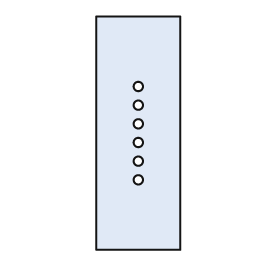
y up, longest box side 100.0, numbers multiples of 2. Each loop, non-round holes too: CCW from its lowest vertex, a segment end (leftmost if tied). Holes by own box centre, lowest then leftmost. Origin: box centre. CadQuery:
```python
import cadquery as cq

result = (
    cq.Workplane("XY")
    .moveTo(-18.0, -50.0)
    .lineTo(18.0, -50.0)
    .lineTo(18.0, 50.0)
    .lineTo(-18.0, 50.0)
    .close()
    .moveTo(0.0, -20.0)
    .circle(2.0)
    .moveTo(0.0, -12.0)
    .circle(2.0)
    .moveTo(0.0, -4.0)
    .circle(2.0)
    .moveTo(0.0, 4.0)
    .circle(2.0)
    .moveTo(0.0, 12.0)
    .circle(2.0)
    .moveTo(0.0, 20.0)
    .circle(2.0)
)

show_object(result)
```